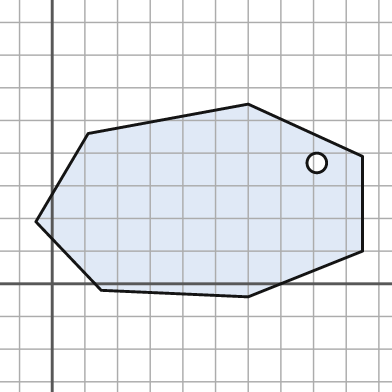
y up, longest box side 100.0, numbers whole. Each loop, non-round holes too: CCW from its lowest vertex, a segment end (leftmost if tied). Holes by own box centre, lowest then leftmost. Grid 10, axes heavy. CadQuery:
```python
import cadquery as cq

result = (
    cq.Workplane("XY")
    .moveTo(60.0, -4.0)
    .lineTo(95.0, 10.0)
    .lineTo(95.0, 39.0)
    .lineTo(60.0, 55.0)
    .lineTo(11.0, 46.0)
    .lineTo(-5.0, 19.0)
    .lineTo(15.0, -2.0)
    .close()
    .moveTo(81.0, 37.0)
    .circle(3.0)
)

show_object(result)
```